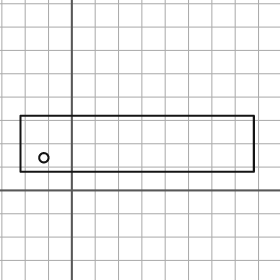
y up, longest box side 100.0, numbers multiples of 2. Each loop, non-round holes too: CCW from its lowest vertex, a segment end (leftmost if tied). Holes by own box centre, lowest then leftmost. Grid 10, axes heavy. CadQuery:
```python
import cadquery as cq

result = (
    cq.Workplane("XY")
    .moveTo(-22.0, 8.0)
    .lineTo(78.0, 8.0)
    .lineTo(78.0, 32.0)
    .lineTo(-22.0, 32.0)
    .close()
    .moveTo(-12.0, 14.0)
    .circle(2.0)
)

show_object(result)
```